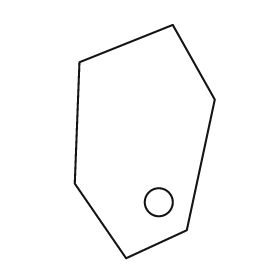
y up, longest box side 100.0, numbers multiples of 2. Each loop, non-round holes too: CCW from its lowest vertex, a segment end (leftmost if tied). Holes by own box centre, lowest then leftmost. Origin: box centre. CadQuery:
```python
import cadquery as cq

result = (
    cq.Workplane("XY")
    .moveTo(-8.0, -50.0)
    .lineTo(18.0, -38.0)
    .lineTo(30.0, 18.0)
    .lineTo(12.0, 50.0)
    .lineTo(-28.0, 34.0)
    .lineTo(-30.0, -18.0)
    .close()
    .moveTo(6.0, -26.0)
    .circle(6.0)
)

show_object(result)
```